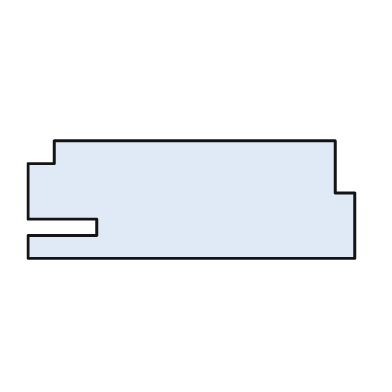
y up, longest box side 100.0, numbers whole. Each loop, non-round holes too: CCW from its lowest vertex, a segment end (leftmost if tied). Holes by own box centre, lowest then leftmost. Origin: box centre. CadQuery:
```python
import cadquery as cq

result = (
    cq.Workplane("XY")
    .moveTo(-50.0, -18.0)
    .lineTo(50.0, -18.0)
    .lineTo(50.0, 2.0)
    .lineTo(44.0, 2.0)
    .lineTo(44.0, 18.0)
    .lineTo(-42.0, 18.0)
    .lineTo(-42.0, 11.0)
    .lineTo(-50.0, 11.0)
    .lineTo(-50.0, -6.0)
    .lineTo(-29.0, -6.0)
    .lineTo(-29.0, -11.0)
    .lineTo(-50.0, -11.0)
    .close()
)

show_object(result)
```